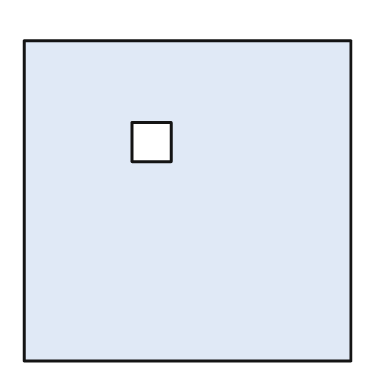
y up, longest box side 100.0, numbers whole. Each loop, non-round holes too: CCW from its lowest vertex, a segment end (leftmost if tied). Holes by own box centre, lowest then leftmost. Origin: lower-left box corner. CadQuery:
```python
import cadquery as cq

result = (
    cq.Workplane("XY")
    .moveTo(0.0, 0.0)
    .lineTo(100.0, 0.0)
    .lineTo(100.0, 98.0)
    .lineTo(0.0, 98.0)
    .close()
    .moveTo(33.0, 61.0)
    .lineTo(45.0, 61.0)
    .lineTo(45.0, 73.0)
    .lineTo(33.0, 73.0)
    .close()
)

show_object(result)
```